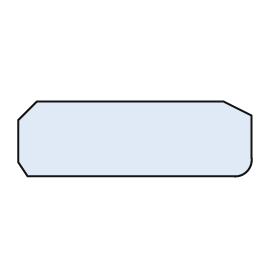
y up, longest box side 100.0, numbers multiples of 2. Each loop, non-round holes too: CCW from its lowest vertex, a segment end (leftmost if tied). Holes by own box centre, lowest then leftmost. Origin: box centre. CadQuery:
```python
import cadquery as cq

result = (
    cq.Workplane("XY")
    .moveTo(-46.0, -16.0)
    .lineTo(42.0, -16.0)
    .threePointArc((48.0, -14.0), (50.0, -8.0))
    .lineTo(50.0, 10.0)
    .lineTo(38.0, 16.0)
    .lineTo(-42.0, 16.0)
    .lineTo(-50.0, 8.0)
    .lineTo(-50.0, -10.0)
    .close()
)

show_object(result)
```